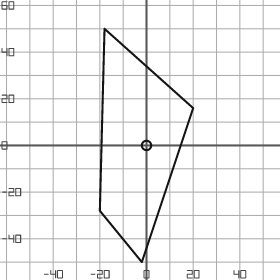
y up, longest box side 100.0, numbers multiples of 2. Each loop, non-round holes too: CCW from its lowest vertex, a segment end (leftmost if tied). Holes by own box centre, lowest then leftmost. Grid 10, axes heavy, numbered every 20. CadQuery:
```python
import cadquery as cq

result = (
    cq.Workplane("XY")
    .moveTo(-2.0, -50.0)
    .lineTo(20.0, 16.0)
    .lineTo(-18.0, 50.0)
    .lineTo(-20.0, -28.0)
    .close()
    .moveTo(0.0, 0.0)
    .circle(2.0)
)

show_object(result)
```